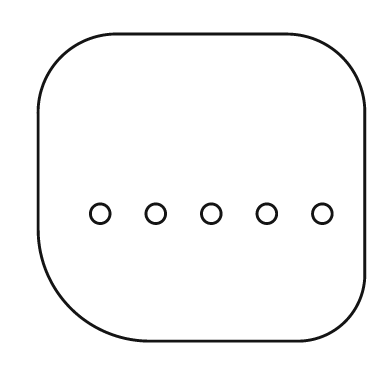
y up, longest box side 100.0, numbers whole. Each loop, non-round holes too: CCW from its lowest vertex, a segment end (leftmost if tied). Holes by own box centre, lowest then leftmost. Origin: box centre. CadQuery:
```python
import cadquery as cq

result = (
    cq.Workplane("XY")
    .moveTo(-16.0, -47.0)
    .lineTo(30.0, -47.0)
    .threePointArc((44.0, -41.0), (50.0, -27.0))
    .lineTo(50.0, 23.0)
    .threePointArc((43.0, 40.0), (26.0, 47.0))
    .lineTo(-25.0, 47.0)
    .threePointArc((-43.0, 40.0), (-50.0, 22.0))
    .lineTo(-50.0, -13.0)
    .threePointArc((-40.0, -37.0), (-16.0, -47.0))
    .close()
    .moveTo(-31.0, -8.0)
    .circle(3.0)
    .moveTo(-14.0, -8.0)
    .circle(3.0)
    .moveTo(3.0, -8.0)
    .circle(3.0)
    .moveTo(20.0, -8.0)
    .circle(3.0)
    .moveTo(37.0, -8.0)
    .circle(3.0)
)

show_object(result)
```